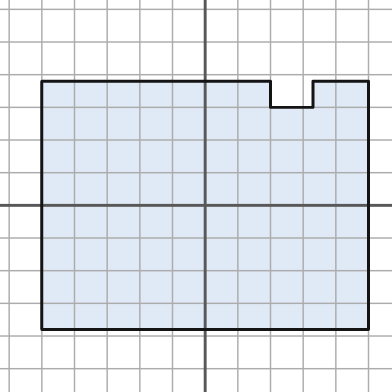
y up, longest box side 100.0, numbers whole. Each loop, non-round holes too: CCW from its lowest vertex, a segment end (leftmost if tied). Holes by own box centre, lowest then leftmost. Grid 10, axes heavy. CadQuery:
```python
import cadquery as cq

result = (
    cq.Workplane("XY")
    .moveTo(-50.0, -38.0)
    .lineTo(50.0, -38.0)
    .lineTo(50.0, 38.0)
    .lineTo(33.0, 38.0)
    .lineTo(33.0, 30.0)
    .lineTo(20.0, 30.0)
    .lineTo(20.0, 38.0)
    .lineTo(-50.0, 38.0)
    .close()
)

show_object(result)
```